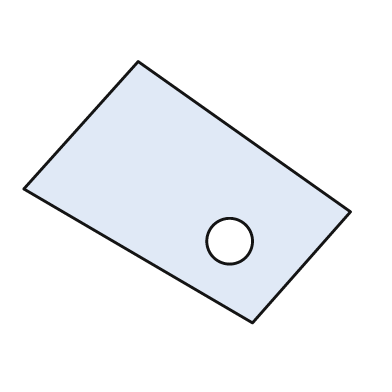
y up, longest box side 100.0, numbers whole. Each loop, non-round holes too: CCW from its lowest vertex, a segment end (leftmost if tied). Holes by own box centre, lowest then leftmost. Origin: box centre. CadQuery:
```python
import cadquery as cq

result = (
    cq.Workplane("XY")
    .moveTo(20.0, -40.0)
    .lineTo(50.0, -6.0)
    .lineTo(-15.0, 40.0)
    .lineTo(-50.0, 1.0)
    .close()
    .moveTo(13.0, -15.0)
    .circle(7.0)
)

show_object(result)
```